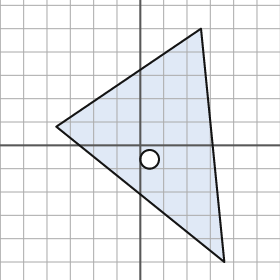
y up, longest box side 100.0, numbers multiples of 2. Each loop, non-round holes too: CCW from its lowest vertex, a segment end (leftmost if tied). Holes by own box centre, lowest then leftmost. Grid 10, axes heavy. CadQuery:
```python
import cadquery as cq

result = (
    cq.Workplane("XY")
    .moveTo(36.0, -50.0)
    .lineTo(26.0, 50.0)
    .lineTo(-36.0, 8.0)
    .close()
    .moveTo(4.0, -6.0)
    .circle(4.0)
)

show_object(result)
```